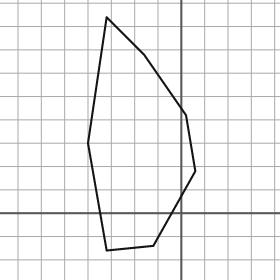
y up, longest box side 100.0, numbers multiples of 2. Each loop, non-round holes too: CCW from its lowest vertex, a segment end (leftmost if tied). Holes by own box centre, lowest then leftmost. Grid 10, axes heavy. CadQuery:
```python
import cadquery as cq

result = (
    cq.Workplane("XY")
    .moveTo(-32.0, -16.0)
    .lineTo(-12.0, -14.0)
    .lineTo(6.0, 18.0)
    .lineTo(2.0, 42.0)
    .lineTo(-16.0, 68.0)
    .lineTo(-32.0, 84.0)
    .lineTo(-40.0, 30.0)
    .close()
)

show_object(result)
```